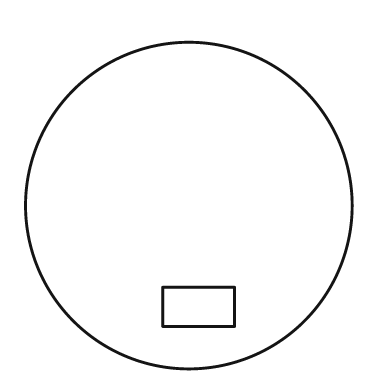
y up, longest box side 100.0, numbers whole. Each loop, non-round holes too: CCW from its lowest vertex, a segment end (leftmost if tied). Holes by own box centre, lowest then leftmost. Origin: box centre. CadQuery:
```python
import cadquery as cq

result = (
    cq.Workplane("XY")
    .moveTo(0.0, 0.0)
    .circle(50.0)
    .moveTo(-8.0, -37.0)
    .lineTo(14.0, -37.0)
    .lineTo(14.0, -25.0)
    .lineTo(-8.0, -25.0)
    .close()
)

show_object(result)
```